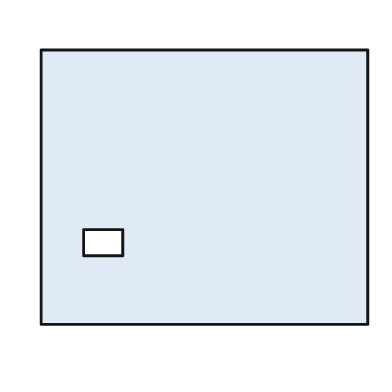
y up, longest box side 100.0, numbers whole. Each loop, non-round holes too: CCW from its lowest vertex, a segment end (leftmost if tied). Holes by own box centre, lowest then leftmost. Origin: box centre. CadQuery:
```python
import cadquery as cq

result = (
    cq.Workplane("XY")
    .moveTo(-50.0, -42.0)
    .lineTo(50.0, -42.0)
    .lineTo(50.0, 42.0)
    .lineTo(-50.0, 42.0)
    .close()
    .moveTo(-37.0, -21.0)
    .lineTo(-25.0, -21.0)
    .lineTo(-25.0, -13.0)
    .lineTo(-37.0, -13.0)
    .close()
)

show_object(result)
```